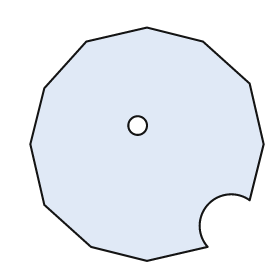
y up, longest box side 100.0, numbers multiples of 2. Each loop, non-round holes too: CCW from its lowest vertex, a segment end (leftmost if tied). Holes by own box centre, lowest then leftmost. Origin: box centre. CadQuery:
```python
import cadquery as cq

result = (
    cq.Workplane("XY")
    .moveTo(0.0, -50.0)
    .lineTo(26.0, -44.0)
    .threePointArc((26.0, -26.0), (44.0, -24.0))
    .lineTo(50.0, 0.0)
    .lineTo(44.0, 26.0)
    .lineTo(24.0, 44.0)
    .lineTo(0.0, 50.0)
    .lineTo(-26.0, 44.0)
    .lineTo(-44.0, 24.0)
    .lineTo(-50.0, 0.0)
    .lineTo(-44.0, -26.0)
    .lineTo(-24.0, -44.0)
    .close()
    .moveTo(-4.0, 8.0)
    .circle(4.0)
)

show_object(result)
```